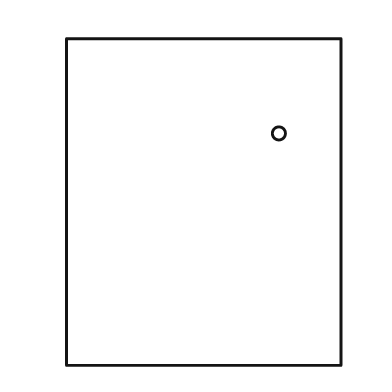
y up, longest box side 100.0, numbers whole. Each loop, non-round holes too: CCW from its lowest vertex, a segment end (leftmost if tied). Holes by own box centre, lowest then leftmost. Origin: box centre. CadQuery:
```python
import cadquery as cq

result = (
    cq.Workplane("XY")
    .moveTo(-42.0, -50.0)
    .lineTo(42.0, -50.0)
    .lineTo(42.0, 50.0)
    .lineTo(-42.0, 50.0)
    .close()
    .moveTo(23.0, 21.0)
    .circle(2.0)
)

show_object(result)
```